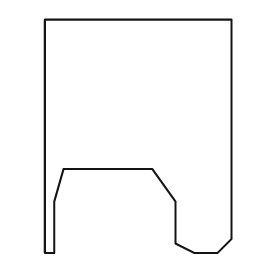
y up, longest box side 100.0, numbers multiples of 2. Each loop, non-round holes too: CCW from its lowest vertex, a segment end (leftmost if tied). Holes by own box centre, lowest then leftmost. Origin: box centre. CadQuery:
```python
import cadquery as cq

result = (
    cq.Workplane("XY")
    .moveTo(-40.0, -50.0)
    .lineTo(-36.0, -50.0)
    .lineTo(-36.0, -28.0)
    .lineTo(-32.0, -14.0)
    .lineTo(6.0, -14.0)
    .lineTo(16.0, -28.0)
    .lineTo(16.0, -46.0)
    .lineTo(24.0, -50.0)
    .lineTo(34.0, -50.0)
    .lineTo(40.0, -44.0)
    .lineTo(40.0, 50.0)
    .lineTo(-40.0, 50.0)
    .close()
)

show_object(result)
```